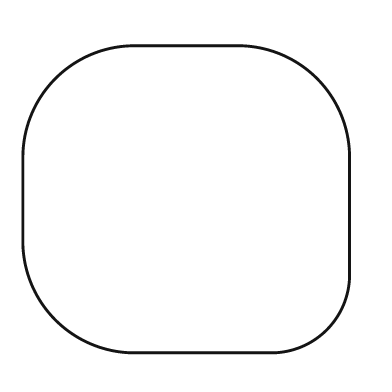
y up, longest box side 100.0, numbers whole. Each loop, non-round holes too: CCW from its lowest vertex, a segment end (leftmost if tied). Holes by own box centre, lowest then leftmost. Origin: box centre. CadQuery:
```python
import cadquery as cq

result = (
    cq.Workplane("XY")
    .moveTo(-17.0, -47.0)
    .lineTo(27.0, -47.0)
    .threePointArc((43.0, -40.0), (50.0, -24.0))
    .lineTo(50.0, 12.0)
    .threePointArc((40.0, 37.0), (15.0, 47.0))
    .lineTo(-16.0, 47.0)
    .threePointArc((-40.0, 37.0), (-50.0, 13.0))
    .lineTo(-50.0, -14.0)
    .threePointArc((-40.0, -37.0), (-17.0, -47.0))
    .close()
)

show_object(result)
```